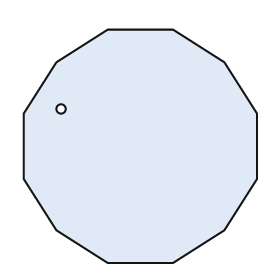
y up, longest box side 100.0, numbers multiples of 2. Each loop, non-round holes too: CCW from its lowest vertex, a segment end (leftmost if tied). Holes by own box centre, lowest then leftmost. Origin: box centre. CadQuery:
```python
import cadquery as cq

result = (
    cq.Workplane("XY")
    .moveTo(-14.0, -50.0)
    .lineTo(14.0, -50.0)
    .lineTo(36.0, -36.0)
    .lineTo(50.0, -14.0)
    .lineTo(50.0, 14.0)
    .lineTo(36.0, 36.0)
    .lineTo(14.0, 50.0)
    .lineTo(-14.0, 50.0)
    .lineTo(-36.0, 36.0)
    .lineTo(-50.0, 14.0)
    .lineTo(-50.0, -14.0)
    .lineTo(-36.0, -36.0)
    .close()
    .moveTo(-34.0, 16.0)
    .circle(2.0)
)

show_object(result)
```